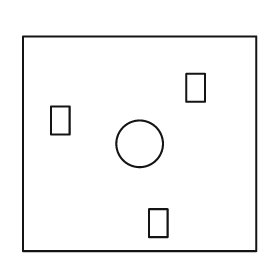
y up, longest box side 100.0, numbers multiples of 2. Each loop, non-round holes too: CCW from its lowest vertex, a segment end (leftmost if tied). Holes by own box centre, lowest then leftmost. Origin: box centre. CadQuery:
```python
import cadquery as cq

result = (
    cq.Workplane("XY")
    .moveTo(-50.0, -46.0)
    .lineTo(50.0, -46.0)
    .lineTo(50.0, 46.0)
    .lineTo(-50.0, 46.0)
    .close()
    .moveTo(4.0, -40.0)
    .lineTo(12.0, -40.0)
    .lineTo(12.0, -28.0)
    .lineTo(4.0, -28.0)
    .close()
    .moveTo(0.0, 0.0)
    .circle(10.0)
    .moveTo(-38.0, 4.0)
    .lineTo(-30.0, 4.0)
    .lineTo(-30.0, 16.0)
    .lineTo(-38.0, 16.0)
    .close()
    .moveTo(20.0, 18.0)
    .lineTo(28.0, 18.0)
    .lineTo(28.0, 30.0)
    .lineTo(20.0, 30.0)
    .close()
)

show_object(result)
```